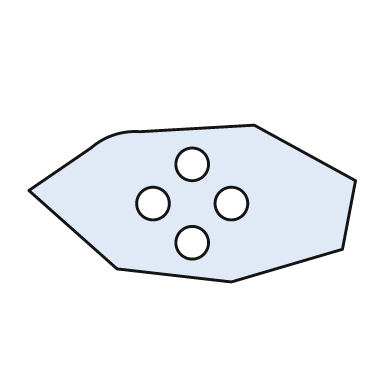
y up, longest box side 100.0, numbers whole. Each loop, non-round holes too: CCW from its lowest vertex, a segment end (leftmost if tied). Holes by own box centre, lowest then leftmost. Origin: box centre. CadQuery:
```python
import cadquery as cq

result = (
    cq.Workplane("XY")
    .moveTo(12.0, -24.0)
    .lineTo(46.0, -14.0)
    .lineTo(50.0, 7.0)
    .lineTo(19.0, 24.0)
    .lineTo(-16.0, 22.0)
    .threePointArc((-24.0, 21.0), (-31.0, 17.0))
    .lineTo(-50.0, 4.0)
    .lineTo(-23.0, -20.0)
    .close()
    .moveTo(0.0, -12.0)
    .circle(5.0)
    .moveTo(-12.0, 0.0)
    .circle(5.0)
    .moveTo(12.0, 0.0)
    .circle(5.0)
    .moveTo(0.0, 12.0)
    .circle(5.0)
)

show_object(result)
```